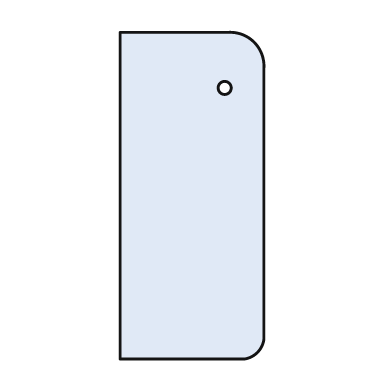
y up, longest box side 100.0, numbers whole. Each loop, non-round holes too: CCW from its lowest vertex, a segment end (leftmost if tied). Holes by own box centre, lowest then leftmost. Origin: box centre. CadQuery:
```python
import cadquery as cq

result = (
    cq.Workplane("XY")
    .moveTo(-22.0, -50.0)
    .lineTo(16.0, -50.0)
    .threePointArc((20.0, -48.0), (22.0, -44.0))
    .lineTo(22.0, 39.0)
    .threePointArc((19.0, 47.0), (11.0, 50.0))
    .lineTo(-22.0, 50.0)
    .close()
    .moveTo(10.0, 33.0)
    .circle(2.0)
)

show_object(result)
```